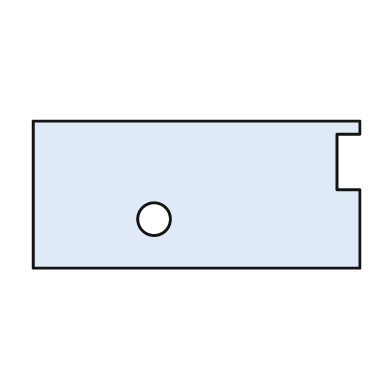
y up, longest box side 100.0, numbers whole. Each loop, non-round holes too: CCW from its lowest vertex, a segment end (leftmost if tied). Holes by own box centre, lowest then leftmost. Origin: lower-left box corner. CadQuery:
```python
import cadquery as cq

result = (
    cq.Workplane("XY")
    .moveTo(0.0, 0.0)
    .lineTo(100.0, 0.0)
    .lineTo(100.0, 24.0)
    .lineTo(93.0, 24.0)
    .lineTo(93.0, 41.0)
    .lineTo(100.0, 41.0)
    .lineTo(100.0, 45.0)
    .lineTo(0.0, 45.0)
    .close()
    .moveTo(37.0, 15.0)
    .circle(5.0)
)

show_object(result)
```